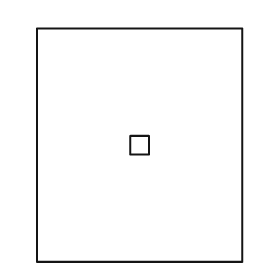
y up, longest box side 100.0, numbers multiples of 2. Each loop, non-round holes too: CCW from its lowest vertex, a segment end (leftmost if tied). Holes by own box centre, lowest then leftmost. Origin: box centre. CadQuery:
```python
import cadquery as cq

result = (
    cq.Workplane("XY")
    .moveTo(-44.0, -50.0)
    .lineTo(44.0, -50.0)
    .lineTo(44.0, 50.0)
    .lineTo(-44.0, 50.0)
    .close()
    .moveTo(-4.0, -4.0)
    .lineTo(4.0, -4.0)
    .lineTo(4.0, 4.0)
    .lineTo(-4.0, 4.0)
    .close()
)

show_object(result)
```